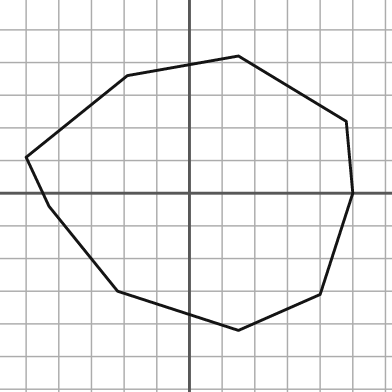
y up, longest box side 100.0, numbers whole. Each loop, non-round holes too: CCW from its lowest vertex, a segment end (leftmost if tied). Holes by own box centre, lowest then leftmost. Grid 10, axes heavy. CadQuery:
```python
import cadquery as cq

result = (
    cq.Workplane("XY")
    .moveTo(15.0, -42.0)
    .lineTo(40.0, -31.0)
    .lineTo(50.0, 0.0)
    .lineTo(48.0, 22.0)
    .lineTo(15.0, 42.0)
    .lineTo(-19.0, 36.0)
    .lineTo(-50.0, 11.0)
    .lineTo(-43.0, -4.0)
    .lineTo(-22.0, -30.0)
    .close()
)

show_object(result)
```